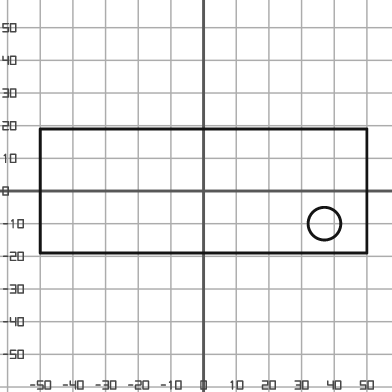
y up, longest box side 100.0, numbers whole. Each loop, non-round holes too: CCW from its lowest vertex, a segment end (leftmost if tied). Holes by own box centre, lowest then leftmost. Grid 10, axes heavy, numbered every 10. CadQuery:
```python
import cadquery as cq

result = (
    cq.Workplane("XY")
    .moveTo(-50.0, -19.0)
    .lineTo(50.0, -19.0)
    .lineTo(50.0, 19.0)
    .lineTo(-50.0, 19.0)
    .close()
    .moveTo(37.0, -10.0)
    .circle(5.0)
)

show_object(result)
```